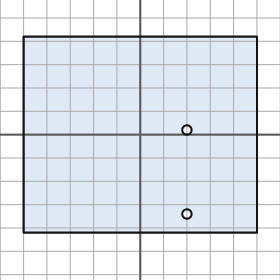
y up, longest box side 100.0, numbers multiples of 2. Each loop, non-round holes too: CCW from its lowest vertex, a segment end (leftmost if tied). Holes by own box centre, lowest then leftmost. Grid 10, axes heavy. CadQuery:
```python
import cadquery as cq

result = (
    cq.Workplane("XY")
    .moveTo(-50.0, -42.0)
    .lineTo(50.0, -42.0)
    .lineTo(50.0, 42.0)
    .lineTo(-50.0, 42.0)
    .close()
    .moveTo(20.0, -34.0)
    .circle(2.0)
    .moveTo(20.0, 2.0)
    .circle(2.0)
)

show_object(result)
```